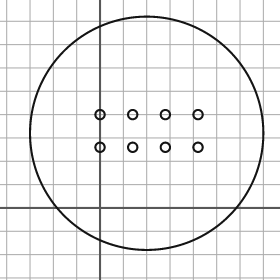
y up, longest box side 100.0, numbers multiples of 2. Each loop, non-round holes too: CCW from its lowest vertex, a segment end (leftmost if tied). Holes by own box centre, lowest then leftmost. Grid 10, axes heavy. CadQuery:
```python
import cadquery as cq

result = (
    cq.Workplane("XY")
    .moveTo(20.0, 32.0)
    .circle(50.0)
    .moveTo(0.0, 26.0)
    .circle(2.0)
    .moveTo(14.0, 26.0)
    .circle(2.0)
    .moveTo(28.0, 26.0)
    .circle(2.0)
    .moveTo(42.0, 26.0)
    .circle(2.0)
    .moveTo(0.0, 40.0)
    .circle(2.0)
    .moveTo(14.0, 40.0)
    .circle(2.0)
    .moveTo(28.0, 40.0)
    .circle(2.0)
    .moveTo(42.0, 40.0)
    .circle(2.0)
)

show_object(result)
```